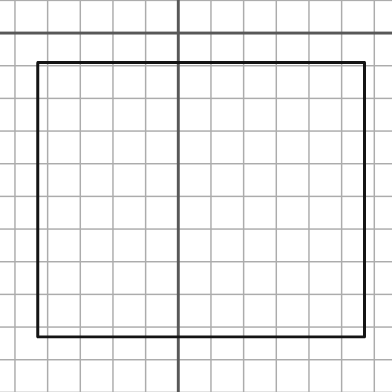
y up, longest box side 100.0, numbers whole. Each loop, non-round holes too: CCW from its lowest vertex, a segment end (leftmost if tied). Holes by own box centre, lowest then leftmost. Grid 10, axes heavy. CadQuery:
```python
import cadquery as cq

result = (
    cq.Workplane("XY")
    .moveTo(-43.0, -93.0)
    .lineTo(57.0, -93.0)
    .lineTo(57.0, -9.0)
    .lineTo(-43.0, -9.0)
    .close()
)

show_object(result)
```